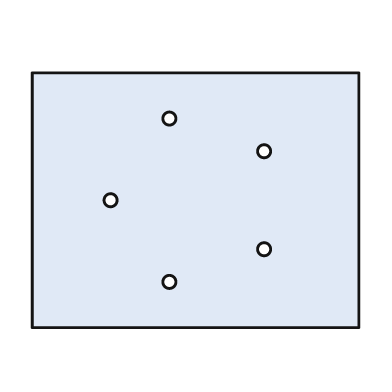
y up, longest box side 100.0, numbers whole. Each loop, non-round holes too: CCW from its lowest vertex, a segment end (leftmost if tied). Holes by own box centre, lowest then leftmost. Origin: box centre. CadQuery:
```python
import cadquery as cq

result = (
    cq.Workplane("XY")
    .moveTo(-50.0, -39.0)
    .lineTo(50.0, -39.0)
    .lineTo(50.0, 39.0)
    .lineTo(-50.0, 39.0)
    .close()
    .moveTo(-8.0, -25.0)
    .circle(2.0)
    .moveTo(21.0, -15.0)
    .circle(2.0)
    .moveTo(-26.0, 0.0)
    .circle(2.0)
    .moveTo(21.0, 15.0)
    .circle(2.0)
    .moveTo(-8.0, 25.0)
    .circle(2.0)
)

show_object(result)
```